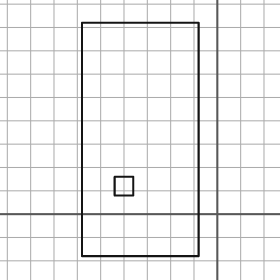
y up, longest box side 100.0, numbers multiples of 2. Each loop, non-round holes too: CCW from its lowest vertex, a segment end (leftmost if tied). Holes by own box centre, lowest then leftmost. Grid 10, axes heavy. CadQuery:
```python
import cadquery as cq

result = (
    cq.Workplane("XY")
    .moveTo(-58.0, -18.0)
    .lineTo(-8.0, -18.0)
    .lineTo(-8.0, 82.0)
    .lineTo(-58.0, 82.0)
    .close()
    .moveTo(-44.0, 8.0)
    .lineTo(-36.0, 8.0)
    .lineTo(-36.0, 16.0)
    .lineTo(-44.0, 16.0)
    .close()
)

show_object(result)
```